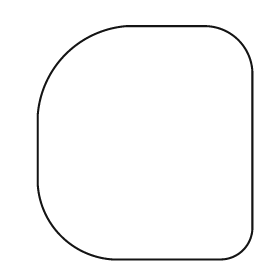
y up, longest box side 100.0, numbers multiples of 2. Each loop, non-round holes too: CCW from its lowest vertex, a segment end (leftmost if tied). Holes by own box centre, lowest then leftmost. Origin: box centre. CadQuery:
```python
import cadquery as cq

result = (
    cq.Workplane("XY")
    .moveTo(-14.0, -50.0)
    .lineTo(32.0, -50.0)
    .threePointArc((42.0, -46.0), (46.0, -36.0))
    .lineTo(46.0, 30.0)
    .threePointArc((40.0, 44.0), (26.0, 50.0))
    .lineTo(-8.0, 50.0)
    .threePointArc((-34.0, 38.0), (-46.0, 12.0))
    .lineTo(-46.0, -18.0)
    .threePointArc((-36.0, -40.0), (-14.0, -50.0))
    .close()
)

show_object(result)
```